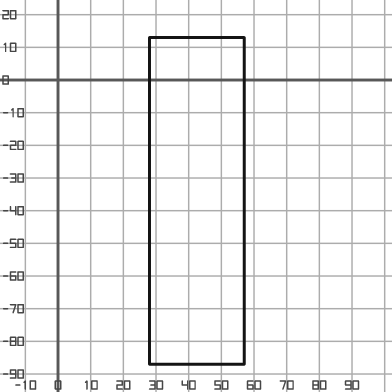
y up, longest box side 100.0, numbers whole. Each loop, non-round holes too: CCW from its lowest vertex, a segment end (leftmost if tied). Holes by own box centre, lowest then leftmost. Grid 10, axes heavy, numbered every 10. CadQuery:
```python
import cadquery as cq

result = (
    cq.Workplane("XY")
    .moveTo(28.0, -87.0)
    .lineTo(57.0, -87.0)
    .lineTo(57.0, 13.0)
    .lineTo(28.0, 13.0)
    .close()
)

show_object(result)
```